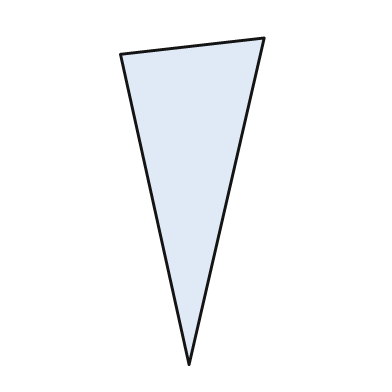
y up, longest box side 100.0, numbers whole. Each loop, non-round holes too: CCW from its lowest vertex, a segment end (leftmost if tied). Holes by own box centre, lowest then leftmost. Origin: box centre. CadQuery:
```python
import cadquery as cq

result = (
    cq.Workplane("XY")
    .moveTo(-1.0, -50.0)
    .lineTo(22.0, 50.0)
    .lineTo(-22.0, 45.0)
    .close()
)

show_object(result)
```